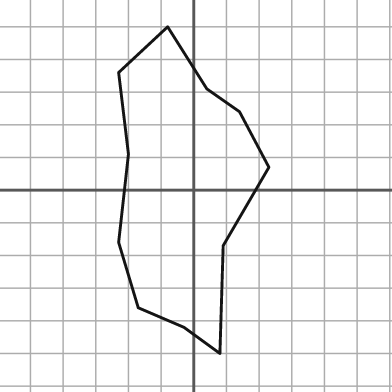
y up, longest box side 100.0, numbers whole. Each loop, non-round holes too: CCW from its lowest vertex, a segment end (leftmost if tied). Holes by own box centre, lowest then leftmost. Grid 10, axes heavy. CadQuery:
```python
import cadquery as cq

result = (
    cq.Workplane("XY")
    .moveTo(8.0, -50.0)
    .lineTo(9.0, -17.0)
    .lineTo(23.0, 7.0)
    .lineTo(14.0, 24.0)
    .lineTo(4.0, 31.0)
    .lineTo(-8.0, 50.0)
    .lineTo(-23.0, 36.0)
    .lineTo(-20.0, 11.0)
    .lineTo(-23.0, -16.0)
    .lineTo(-17.0, -36.0)
    .lineTo(-3.0, -42.0)
    .close()
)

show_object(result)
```